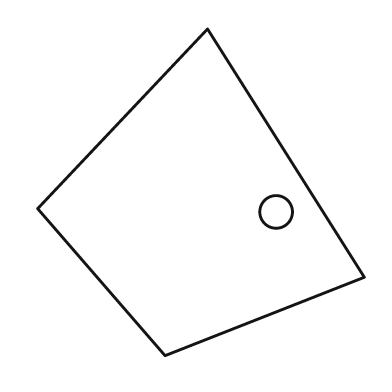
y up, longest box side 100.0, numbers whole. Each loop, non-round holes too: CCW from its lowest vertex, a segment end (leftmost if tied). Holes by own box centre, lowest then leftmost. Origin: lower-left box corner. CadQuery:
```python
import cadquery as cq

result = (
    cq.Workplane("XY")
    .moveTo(39.0, 0.0)
    .lineTo(100.0, 24.0)
    .lineTo(52.0, 100.0)
    .lineTo(0.0, 45.0)
    .close()
    .moveTo(73.0, 44.0)
    .circle(5.0)
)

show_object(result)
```